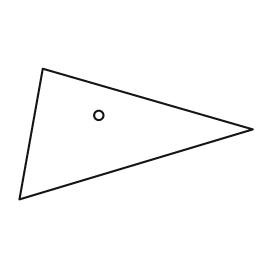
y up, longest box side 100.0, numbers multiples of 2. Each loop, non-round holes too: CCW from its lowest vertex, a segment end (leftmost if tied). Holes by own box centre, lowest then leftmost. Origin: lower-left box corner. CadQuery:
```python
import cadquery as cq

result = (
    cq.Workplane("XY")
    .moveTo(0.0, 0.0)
    .lineTo(100.0, 30.0)
    .lineTo(10.0, 56.0)
    .close()
    .moveTo(34.0, 36.0)
    .circle(2.0)
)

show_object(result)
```